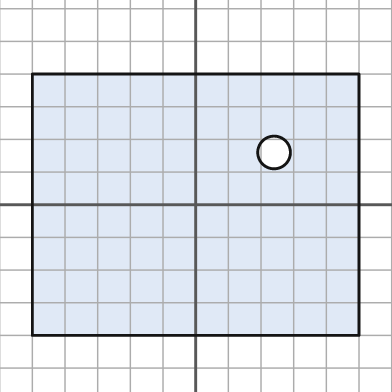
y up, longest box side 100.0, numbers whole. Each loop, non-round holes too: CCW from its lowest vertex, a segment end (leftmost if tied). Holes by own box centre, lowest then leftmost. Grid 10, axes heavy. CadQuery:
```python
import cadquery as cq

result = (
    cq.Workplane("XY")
    .moveTo(-50.0, -40.0)
    .lineTo(50.0, -40.0)
    .lineTo(50.0, 40.0)
    .lineTo(-50.0, 40.0)
    .close()
    .moveTo(24.0, 16.0)
    .circle(5.0)
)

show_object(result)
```